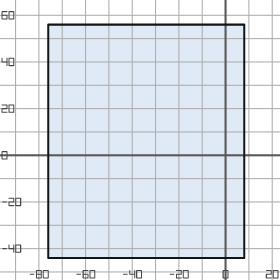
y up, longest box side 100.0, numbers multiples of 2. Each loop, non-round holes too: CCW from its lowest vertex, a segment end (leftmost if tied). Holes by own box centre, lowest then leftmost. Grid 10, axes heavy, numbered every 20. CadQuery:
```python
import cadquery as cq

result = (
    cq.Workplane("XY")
    .moveTo(-76.0, -44.0)
    .lineTo(8.0, -44.0)
    .lineTo(8.0, 56.0)
    .lineTo(-76.0, 56.0)
    .close()
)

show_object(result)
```